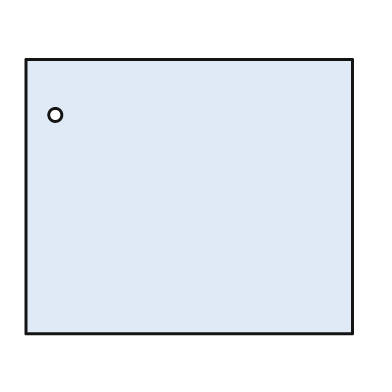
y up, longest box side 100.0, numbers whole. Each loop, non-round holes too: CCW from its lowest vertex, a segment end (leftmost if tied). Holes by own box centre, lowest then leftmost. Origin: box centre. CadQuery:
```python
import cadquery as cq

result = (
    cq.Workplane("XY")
    .moveTo(-50.0, -42.0)
    .lineTo(50.0, -42.0)
    .lineTo(50.0, 42.0)
    .lineTo(-50.0, 42.0)
    .close()
    .moveTo(-41.0, 25.0)
    .circle(2.0)
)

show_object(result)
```